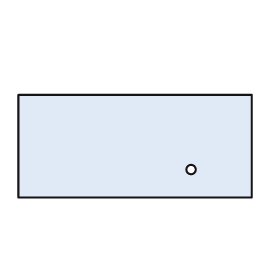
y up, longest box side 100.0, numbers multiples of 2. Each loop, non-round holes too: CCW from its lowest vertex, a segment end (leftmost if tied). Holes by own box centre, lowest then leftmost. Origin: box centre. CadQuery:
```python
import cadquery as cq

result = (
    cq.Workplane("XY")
    .moveTo(-50.0, -22.0)
    .lineTo(50.0, -22.0)
    .lineTo(50.0, 22.0)
    .lineTo(-50.0, 22.0)
    .close()
    .moveTo(24.0, -10.0)
    .circle(2.0)
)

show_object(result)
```